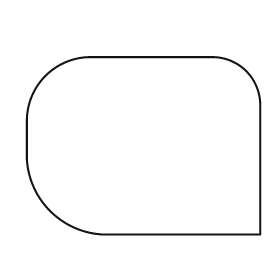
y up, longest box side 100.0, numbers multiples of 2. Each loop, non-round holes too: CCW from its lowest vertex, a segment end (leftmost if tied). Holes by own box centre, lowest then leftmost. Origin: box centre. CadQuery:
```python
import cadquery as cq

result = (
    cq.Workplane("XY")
    .moveTo(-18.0, -38.0)
    .lineTo(50.0, -38.0)
    .lineTo(50.0, 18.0)
    .threePointArc((44.0, 32.0), (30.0, 38.0))
    .lineTo(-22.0, 38.0)
    .threePointArc((-42.0, 30.0), (-50.0, 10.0))
    .lineTo(-50.0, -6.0)
    .threePointArc((-40.0, -28.0), (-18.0, -38.0))
    .close()
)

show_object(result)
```